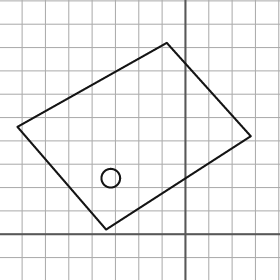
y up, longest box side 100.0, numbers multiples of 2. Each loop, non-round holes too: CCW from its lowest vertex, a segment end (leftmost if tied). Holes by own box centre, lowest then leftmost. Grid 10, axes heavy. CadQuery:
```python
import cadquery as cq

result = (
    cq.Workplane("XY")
    .moveTo(-34.0, 2.0)
    .lineTo(28.0, 42.0)
    .lineTo(-8.0, 82.0)
    .lineTo(-72.0, 46.0)
    .close()
    .moveTo(-32.0, 24.0)
    .circle(4.0)
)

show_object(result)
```